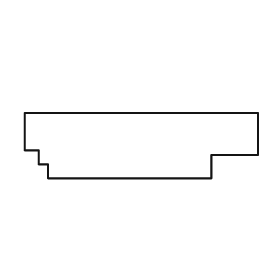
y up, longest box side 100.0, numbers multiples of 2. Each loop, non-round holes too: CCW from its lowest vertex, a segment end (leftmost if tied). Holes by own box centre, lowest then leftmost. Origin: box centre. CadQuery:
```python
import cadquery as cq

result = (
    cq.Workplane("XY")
    .moveTo(-40.0, -14.0)
    .lineTo(30.0, -14.0)
    .lineTo(30.0, -4.0)
    .lineTo(50.0, -4.0)
    .lineTo(50.0, 14.0)
    .lineTo(-50.0, 14.0)
    .lineTo(-50.0, -2.0)
    .lineTo(-44.0, -2.0)
    .lineTo(-44.0, -8.0)
    .lineTo(-40.0, -8.0)
    .close()
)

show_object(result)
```